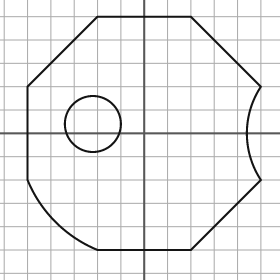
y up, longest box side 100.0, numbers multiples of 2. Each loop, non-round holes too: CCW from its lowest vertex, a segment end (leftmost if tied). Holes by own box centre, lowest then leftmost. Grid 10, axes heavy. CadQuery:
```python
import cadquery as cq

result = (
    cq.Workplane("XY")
    .moveTo(-20.0, -50.0)
    .lineTo(20.0, -50.0)
    .lineTo(50.0, -20.0)
    .threePointArc((44.0, 0.0), (50.0, 20.0))
    .lineTo(20.0, 50.0)
    .lineTo(-20.0, 50.0)
    .lineTo(-50.0, 20.0)
    .lineTo(-50.0, -20.0)
    .threePointArc((-38.0, -38.0), (-20.0, -50.0))
    .close()
    .moveTo(-22.0, 4.0)
    .circle(12.0)
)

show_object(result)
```